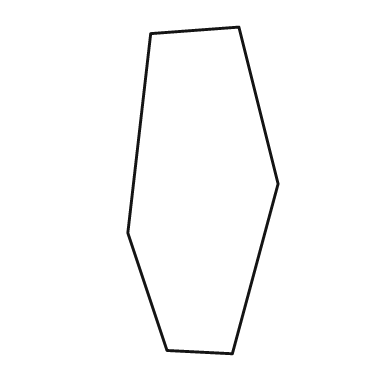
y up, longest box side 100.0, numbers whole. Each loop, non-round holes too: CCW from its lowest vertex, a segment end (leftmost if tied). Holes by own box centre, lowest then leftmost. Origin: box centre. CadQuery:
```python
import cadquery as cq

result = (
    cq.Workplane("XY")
    .moveTo(9.0, -50.0)
    .lineTo(23.0, 2.0)
    .lineTo(11.0, 50.0)
    .lineTo(-16.0, 48.0)
    .lineTo(-23.0, -13.0)
    .lineTo(-11.0, -49.0)
    .close()
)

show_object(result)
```